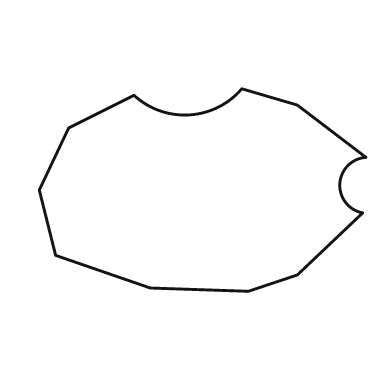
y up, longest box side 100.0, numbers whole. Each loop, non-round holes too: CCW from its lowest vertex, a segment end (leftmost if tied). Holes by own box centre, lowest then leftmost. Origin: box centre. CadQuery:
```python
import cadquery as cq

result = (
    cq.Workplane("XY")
    .moveTo(14.0, -31.0)
    .lineTo(29.0, -26.0)
    .lineTo(49.0, -7.0)
    .threePointArc((42.0, 2.0), (50.0, 10.0))
    .lineTo(29.0, 26.0)
    .lineTo(12.0, 31.0)
    .threePointArc((-4.0, 23.0), (-21.0, 29.0))
    .lineTo(-41.0, 19.0)
    .lineTo(-50.0, 0.0)
    .lineTo(-45.0, -20.0)
    .lineTo(-16.0, -30.0)
    .close()
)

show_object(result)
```